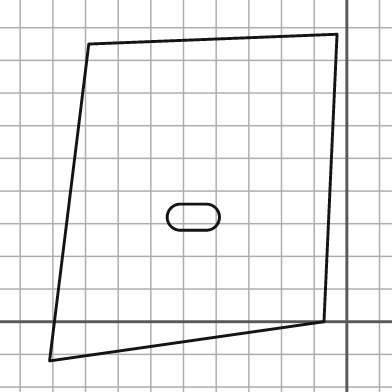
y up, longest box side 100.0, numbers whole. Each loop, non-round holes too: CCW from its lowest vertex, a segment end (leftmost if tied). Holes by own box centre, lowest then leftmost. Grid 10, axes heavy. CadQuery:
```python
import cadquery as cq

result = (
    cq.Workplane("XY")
    .moveTo(-91.0, -12.0)
    .lineTo(-7.0, 0.0)
    .lineTo(-3.0, 88.0)
    .lineTo(-79.0, 85.0)
    .close()
    .moveTo(-51.0, 28.0)
    .lineTo(-43.0, 28.0)
    .threePointArc((-39.0, 32.0), (-43.0, 36.0))
    .lineTo(-51.0, 36.0)
    .threePointArc((-55.0, 32.0), (-51.0, 28.0))
    .close()
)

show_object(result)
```